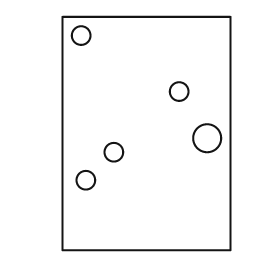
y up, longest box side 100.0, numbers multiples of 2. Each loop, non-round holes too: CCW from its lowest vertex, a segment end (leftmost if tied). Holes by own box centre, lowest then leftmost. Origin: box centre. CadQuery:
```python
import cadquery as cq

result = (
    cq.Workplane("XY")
    .moveTo(-36.0, -50.0)
    .lineTo(36.0, -50.0)
    .lineTo(36.0, 50.0)
    .lineTo(-36.0, 50.0)
    .close()
    .moveTo(-26.0, -20.0)
    .circle(4.0)
    .moveTo(-14.0, -8.0)
    .circle(4.0)
    .moveTo(26.0, -2.0)
    .circle(6.0)
    .moveTo(14.0, 18.0)
    .circle(4.0)
    .moveTo(-28.0, 42.0)
    .circle(4.0)
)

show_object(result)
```